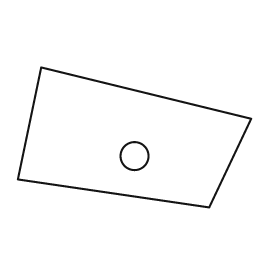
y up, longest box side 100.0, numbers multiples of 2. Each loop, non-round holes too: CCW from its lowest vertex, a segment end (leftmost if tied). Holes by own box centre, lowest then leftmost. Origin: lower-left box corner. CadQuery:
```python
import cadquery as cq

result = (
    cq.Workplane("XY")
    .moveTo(82.0, 0.0)
    .lineTo(100.0, 38.0)
    .lineTo(10.0, 60.0)
    .lineTo(0.0, 12.0)
    .close()
    .moveTo(50.0, 22.0)
    .circle(6.0)
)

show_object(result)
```